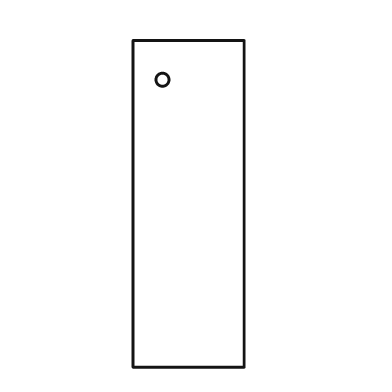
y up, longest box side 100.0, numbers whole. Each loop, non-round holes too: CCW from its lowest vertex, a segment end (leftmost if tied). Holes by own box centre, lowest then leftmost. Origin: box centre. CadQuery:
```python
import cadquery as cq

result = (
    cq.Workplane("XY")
    .moveTo(-17.0, -50.0)
    .lineTo(17.0, -50.0)
    .lineTo(17.0, 50.0)
    .lineTo(-17.0, 50.0)
    .close()
    .moveTo(-8.0, 38.0)
    .circle(2.0)
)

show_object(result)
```